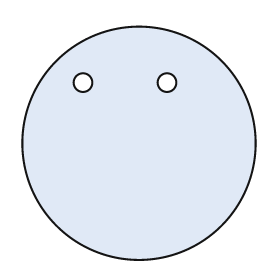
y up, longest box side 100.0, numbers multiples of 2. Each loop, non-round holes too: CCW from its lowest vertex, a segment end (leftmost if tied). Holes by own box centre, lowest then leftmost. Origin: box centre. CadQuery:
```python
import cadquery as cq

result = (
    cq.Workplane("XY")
    .moveTo(0.0, 0.0)
    .circle(50.0)
    .moveTo(-24.0, 26.0)
    .circle(4.0)
    .moveTo(12.0, 26.0)
    .circle(4.0)
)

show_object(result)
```